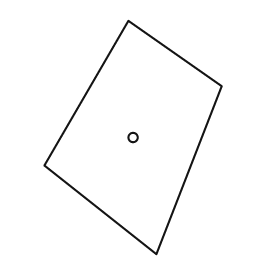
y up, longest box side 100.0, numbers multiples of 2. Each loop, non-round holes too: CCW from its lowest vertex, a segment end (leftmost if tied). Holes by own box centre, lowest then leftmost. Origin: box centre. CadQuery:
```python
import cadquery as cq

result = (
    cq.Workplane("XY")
    .moveTo(10.0, -50.0)
    .lineTo(38.0, 22.0)
    .lineTo(-2.0, 50.0)
    .lineTo(-38.0, -12.0)
    .close()
    .moveTo(0.0, 0.0)
    .circle(2.0)
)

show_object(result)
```